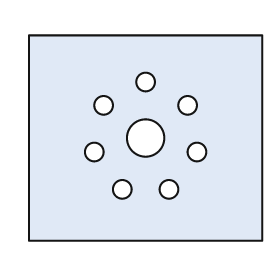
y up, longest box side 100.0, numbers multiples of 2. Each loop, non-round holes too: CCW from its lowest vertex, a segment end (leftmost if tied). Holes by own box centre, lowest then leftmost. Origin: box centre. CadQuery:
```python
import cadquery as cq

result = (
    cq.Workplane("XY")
    .moveTo(-50.0, -44.0)
    .lineTo(50.0, -44.0)
    .lineTo(50.0, 44.0)
    .lineTo(-50.0, 44.0)
    .close()
    .moveTo(-10.0, -22.0)
    .circle(4.0)
    .moveTo(10.0, -22.0)
    .circle(4.0)
    .moveTo(-22.0, -6.0)
    .circle(4.0)
    .moveTo(22.0, -6.0)
    .circle(4.0)
    .moveTo(0.0, 0.0)
    .circle(8.0)
    .moveTo(-18.0, 14.0)
    .circle(4.0)
    .moveTo(18.0, 14.0)
    .circle(4.0)
    .moveTo(0.0, 24.0)
    .circle(4.0)
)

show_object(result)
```